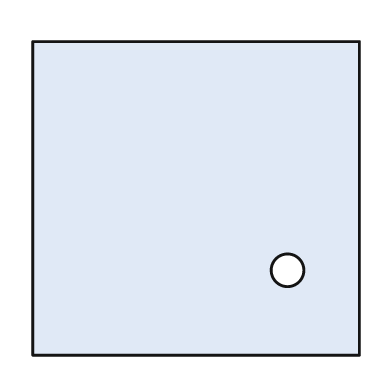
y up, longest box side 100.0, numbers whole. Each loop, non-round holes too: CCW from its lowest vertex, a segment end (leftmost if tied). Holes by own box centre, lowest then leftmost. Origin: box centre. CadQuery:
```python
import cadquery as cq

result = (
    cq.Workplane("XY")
    .moveTo(-50.0, -48.0)
    .lineTo(50.0, -48.0)
    .lineTo(50.0, 48.0)
    .lineTo(-50.0, 48.0)
    .close()
    .moveTo(28.0, -22.0)
    .circle(5.0)
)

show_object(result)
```